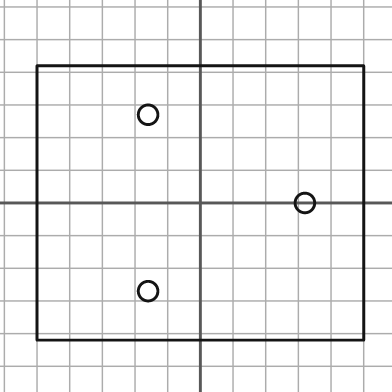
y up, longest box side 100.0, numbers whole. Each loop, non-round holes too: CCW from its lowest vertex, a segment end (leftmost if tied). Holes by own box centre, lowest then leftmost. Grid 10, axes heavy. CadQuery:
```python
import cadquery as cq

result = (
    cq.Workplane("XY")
    .moveTo(-50.0, -42.0)
    .lineTo(50.0, -42.0)
    .lineTo(50.0, 42.0)
    .lineTo(-50.0, 42.0)
    .close()
    .moveTo(-16.0, -27.0)
    .circle(3.0)
    .moveTo(32.0, 0.0)
    .circle(3.0)
    .moveTo(-16.0, 27.0)
    .circle(3.0)
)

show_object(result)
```